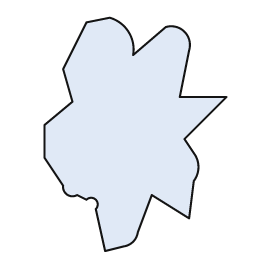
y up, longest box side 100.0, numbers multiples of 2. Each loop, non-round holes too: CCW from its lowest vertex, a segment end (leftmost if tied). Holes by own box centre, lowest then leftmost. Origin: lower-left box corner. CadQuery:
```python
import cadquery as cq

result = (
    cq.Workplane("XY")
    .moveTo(26.0, 0.0)
    .lineTo(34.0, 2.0)
    .threePointArc((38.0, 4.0), (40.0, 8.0))
    .lineTo(46.0, 24.0)
    .lineTo(62.0, 14.0)
    .lineTo(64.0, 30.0)
    .threePointArc((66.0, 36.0), (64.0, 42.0))
    .lineTo(60.0, 48.0)
    .lineTo(78.0, 66.0)
    .lineTo(58.0, 66.0)
    .lineTo(62.0, 86.0)
    .threePointArc((60.0, 94.0), (52.0, 96.0))
    .lineTo(38.0, 84.0)
    .threePointArc((36.0, 94.0), (28.0, 100.0))
    .lineTo(18.0, 98.0)
    .lineTo(8.0, 78.0)
    .lineTo(12.0, 64.0)
    .lineTo(0.0, 54.0)
    .lineTo(0.0, 40.0)
    .lineTo(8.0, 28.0)
    .threePointArc((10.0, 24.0), (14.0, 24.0))
    .lineTo(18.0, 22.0)
    .threePointArc((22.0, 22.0), (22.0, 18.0))
    .close()
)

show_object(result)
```